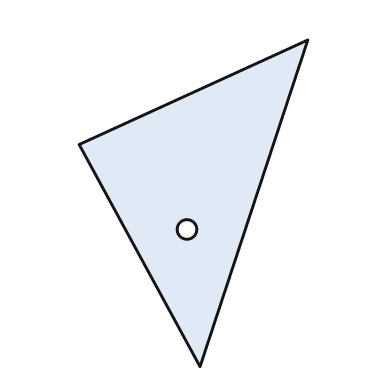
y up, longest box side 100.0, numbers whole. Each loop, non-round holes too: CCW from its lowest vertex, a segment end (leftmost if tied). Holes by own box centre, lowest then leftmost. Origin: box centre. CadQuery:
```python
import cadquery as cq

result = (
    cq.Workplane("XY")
    .moveTo(2.0, -50.0)
    .lineTo(35.0, 50.0)
    .lineTo(-35.0, 18.0)
    .close()
    .moveTo(-2.0, -8.0)
    .circle(3.0)
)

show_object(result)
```